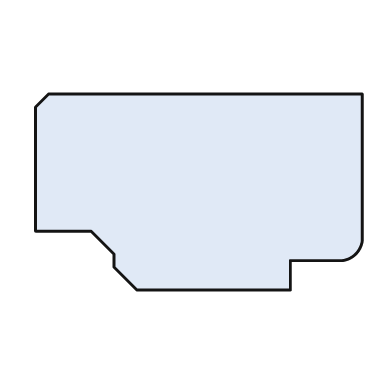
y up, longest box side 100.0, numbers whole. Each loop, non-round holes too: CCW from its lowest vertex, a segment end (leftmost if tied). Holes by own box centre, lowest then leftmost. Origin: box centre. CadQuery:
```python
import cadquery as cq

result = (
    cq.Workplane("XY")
    .moveTo(-19.0, -30.0)
    .lineTo(28.0, -30.0)
    .lineTo(28.0, -21.0)
    .lineTo(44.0, -21.0)
    .threePointArc((48.0, -19.0), (50.0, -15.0))
    .lineTo(50.0, 30.0)
    .lineTo(-46.0, 30.0)
    .lineTo(-50.0, 26.0)
    .lineTo(-50.0, -12.0)
    .lineTo(-33.0, -12.0)
    .lineTo(-26.0, -19.0)
    .lineTo(-26.0, -23.0)
    .close()
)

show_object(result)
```